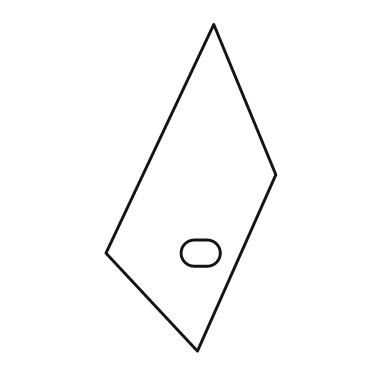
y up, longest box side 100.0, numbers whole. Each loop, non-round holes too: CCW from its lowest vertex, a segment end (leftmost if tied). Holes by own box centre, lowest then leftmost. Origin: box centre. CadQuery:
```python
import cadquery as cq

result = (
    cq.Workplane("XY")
    .moveTo(2.0, -50.0)
    .lineTo(26.0, 4.0)
    .lineTo(7.0, 50.0)
    .lineTo(-26.0, -20.0)
    .close()
    .moveTo(1.0, -24.0)
    .lineTo(5.0, -24.0)
    .threePointArc((9.0, -20.0), (5.0, -16.0))
    .lineTo(1.0, -16.0)
    .threePointArc((-3.0, -20.0), (1.0, -24.0))
    .close()
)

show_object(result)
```